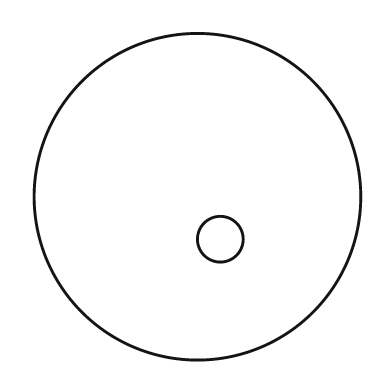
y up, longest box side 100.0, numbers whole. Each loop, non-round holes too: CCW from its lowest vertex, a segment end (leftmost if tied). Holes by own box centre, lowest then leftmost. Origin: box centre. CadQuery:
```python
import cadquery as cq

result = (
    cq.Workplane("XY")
    .moveTo(0.0, 0.0)
    .circle(50.0)
    .moveTo(7.0, -13.0)
    .circle(7.0)
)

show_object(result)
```